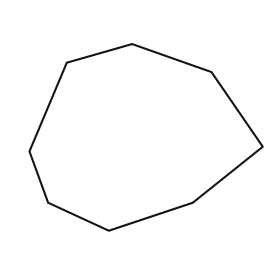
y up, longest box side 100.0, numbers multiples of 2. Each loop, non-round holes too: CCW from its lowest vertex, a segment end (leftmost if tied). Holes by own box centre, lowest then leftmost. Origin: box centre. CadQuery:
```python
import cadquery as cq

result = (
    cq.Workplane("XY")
    .moveTo(-16.0, -40.0)
    .lineTo(20.0, -28.0)
    .lineTo(50.0, -4.0)
    .lineTo(28.0, 28.0)
    .lineTo(-6.0, 40.0)
    .lineTo(-34.0, 32.0)
    .lineTo(-50.0, -6.0)
    .lineTo(-42.0, -28.0)
    .close()
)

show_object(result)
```